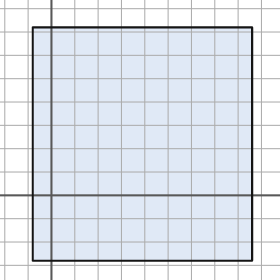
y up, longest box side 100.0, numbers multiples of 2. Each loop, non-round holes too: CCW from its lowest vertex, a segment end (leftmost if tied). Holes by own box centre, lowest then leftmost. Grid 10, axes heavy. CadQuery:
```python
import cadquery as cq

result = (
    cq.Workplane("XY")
    .moveTo(-8.0, -28.0)
    .lineTo(86.0, -28.0)
    .lineTo(86.0, 72.0)
    .lineTo(-8.0, 72.0)
    .close()
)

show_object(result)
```